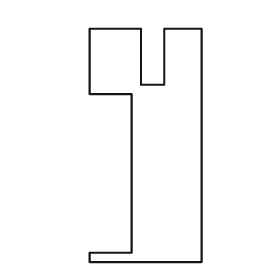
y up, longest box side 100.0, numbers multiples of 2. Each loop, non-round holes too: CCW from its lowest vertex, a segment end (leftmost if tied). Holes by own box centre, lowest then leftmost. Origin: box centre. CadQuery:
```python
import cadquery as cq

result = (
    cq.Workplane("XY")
    .moveTo(-24.0, -50.0)
    .lineTo(24.0, -50.0)
    .lineTo(24.0, 50.0)
    .lineTo(8.0, 50.0)
    .lineTo(8.0, 26.0)
    .lineTo(-2.0, 26.0)
    .lineTo(-2.0, 50.0)
    .lineTo(-24.0, 50.0)
    .lineTo(-24.0, 22.0)
    .lineTo(-6.0, 22.0)
    .lineTo(-6.0, -46.0)
    .lineTo(-24.0, -46.0)
    .close()
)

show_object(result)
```